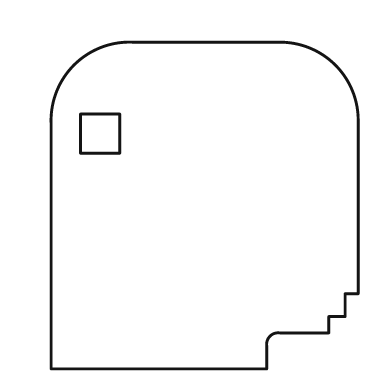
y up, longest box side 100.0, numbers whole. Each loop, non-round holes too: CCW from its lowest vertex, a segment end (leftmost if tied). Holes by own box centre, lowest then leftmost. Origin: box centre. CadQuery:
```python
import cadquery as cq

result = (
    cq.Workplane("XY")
    .moveTo(-47.0, -50.0)
    .lineTo(19.0, -50.0)
    .lineTo(19.0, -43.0)
    .threePointArc((20.0, -40.0), (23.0, -39.0))
    .lineTo(38.0, -39.0)
    .lineTo(38.0, -34.0)
    .lineTo(43.0, -34.0)
    .lineTo(43.0, -27.0)
    .lineTo(47.0, -27.0)
    .lineTo(47.0, 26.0)
    .threePointArc((40.0, 43.0), (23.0, 50.0))
    .lineTo(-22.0, 50.0)
    .threePointArc((-40.0, 43.0), (-47.0, 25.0))
    .close()
    .moveTo(-38.0, 16.0)
    .lineTo(-26.0, 16.0)
    .lineTo(-26.0, 28.0)
    .lineTo(-38.0, 28.0)
    .close()
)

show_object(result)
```